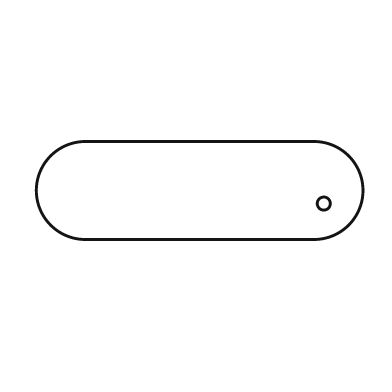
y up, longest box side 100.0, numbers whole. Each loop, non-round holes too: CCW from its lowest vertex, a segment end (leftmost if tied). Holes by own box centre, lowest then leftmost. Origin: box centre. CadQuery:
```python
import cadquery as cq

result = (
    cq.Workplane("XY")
    .moveTo(-35.0, -15.0)
    .lineTo(35.0, -15.0)
    .threePointArc((50.0, 0.0), (35.0, 15.0))
    .lineTo(-35.0, 15.0)
    .threePointArc((-50.0, 0.0), (-35.0, -15.0))
    .close()
    .moveTo(38.0, -4.0)
    .circle(2.0)
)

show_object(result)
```